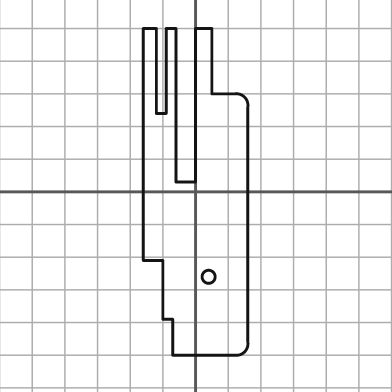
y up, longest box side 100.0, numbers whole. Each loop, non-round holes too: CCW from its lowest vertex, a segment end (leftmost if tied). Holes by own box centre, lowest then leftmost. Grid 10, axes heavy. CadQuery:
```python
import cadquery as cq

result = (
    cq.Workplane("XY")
    .moveTo(-7.0, -50.0)
    .lineTo(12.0, -50.0)
    .threePointArc((15.0, -49.0), (16.0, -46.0))
    .lineTo(16.0, 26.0)
    .threePointArc((15.0, 29.0), (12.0, 30.0))
    .lineTo(5.0, 30.0)
    .lineTo(5.0, 50.0)
    .lineTo(0.0, 50.0)
    .lineTo(0.0, 3.0)
    .lineTo(-6.0, 3.0)
    .lineTo(-6.0, 50.0)
    .lineTo(-9.0, 50.0)
    .lineTo(-9.0, 24.0)
    .lineTo(-12.0, 24.0)
    .lineTo(-12.0, 50.0)
    .lineTo(-16.0, 50.0)
    .lineTo(-16.0, -21.0)
    .lineTo(-10.0, -21.0)
    .lineTo(-10.0, -39.0)
    .lineTo(-7.0, -39.0)
    .close()
    .moveTo(4.0, -26.0)
    .circle(2.0)
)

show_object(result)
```